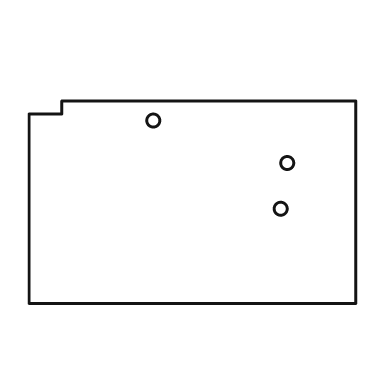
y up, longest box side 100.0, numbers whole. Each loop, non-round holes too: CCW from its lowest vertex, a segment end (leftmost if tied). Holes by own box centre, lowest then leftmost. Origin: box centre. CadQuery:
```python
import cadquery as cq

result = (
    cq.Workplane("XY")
    .moveTo(-50.0, -31.0)
    .lineTo(50.0, -31.0)
    .lineTo(50.0, 31.0)
    .lineTo(-40.0, 31.0)
    .lineTo(-40.0, 27.0)
    .lineTo(-50.0, 27.0)
    .close()
    .moveTo(27.0, -2.0)
    .circle(2.0)
    .moveTo(29.0, 12.0)
    .circle(2.0)
    .moveTo(-12.0, 25.0)
    .circle(2.0)
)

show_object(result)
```